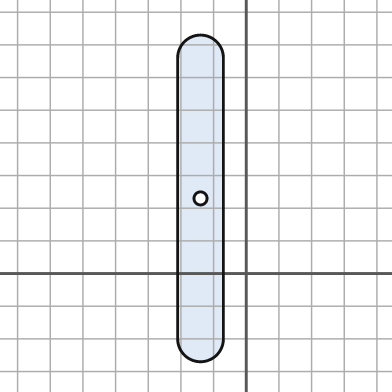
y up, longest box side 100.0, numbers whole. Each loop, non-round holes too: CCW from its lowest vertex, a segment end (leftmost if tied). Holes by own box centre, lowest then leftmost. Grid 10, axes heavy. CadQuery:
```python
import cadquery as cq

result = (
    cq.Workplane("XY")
    .moveTo(-21.0, -20.0)
    .threePointArc((-14.0, -27.0), (-7.0, -20.0))
    .lineTo(-7.0, 66.0)
    .threePointArc((-14.0, 73.0), (-21.0, 66.0))
    .close()
    .moveTo(-14.0, 23.0)
    .circle(2.0)
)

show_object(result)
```